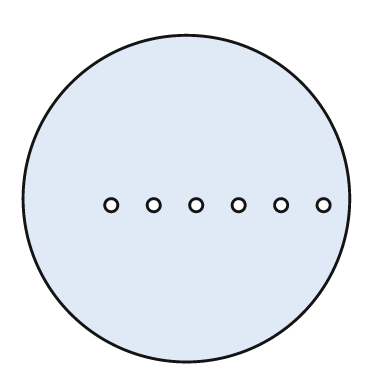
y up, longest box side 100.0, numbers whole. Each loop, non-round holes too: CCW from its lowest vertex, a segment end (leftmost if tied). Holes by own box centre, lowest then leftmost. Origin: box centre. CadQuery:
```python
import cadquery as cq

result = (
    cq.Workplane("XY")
    .moveTo(0.0, 0.0)
    .circle(50.0)
    .moveTo(-23.0, -2.0)
    .circle(2.0)
    .moveTo(-10.0, -2.0)
    .circle(2.0)
    .moveTo(3.0, -2.0)
    .circle(2.0)
    .moveTo(16.0, -2.0)
    .circle(2.0)
    .moveTo(29.0, -2.0)
    .circle(2.0)
    .moveTo(42.0, -2.0)
    .circle(2.0)
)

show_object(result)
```